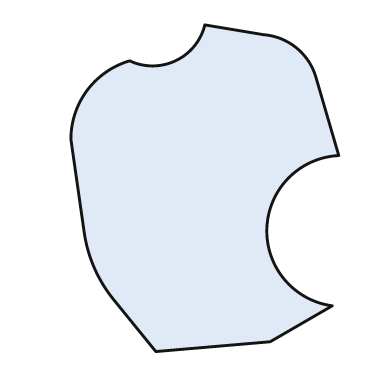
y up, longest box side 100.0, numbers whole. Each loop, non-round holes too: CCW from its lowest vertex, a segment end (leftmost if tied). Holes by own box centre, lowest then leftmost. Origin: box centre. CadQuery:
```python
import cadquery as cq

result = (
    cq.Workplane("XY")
    .moveTo(-15.0, -50.0)
    .lineTo(20.0, -47.0)
    .lineTo(39.0, -36.0)
    .threePointArc((19.0, -12.0), (41.0, 10.0))
    .lineTo(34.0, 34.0)
    .threePointArc((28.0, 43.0), (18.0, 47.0))
    .lineTo(0.0, 50.0)
    .threePointArc((-9.0, 39.0), (-23.0, 39.0))
    .threePointArc((-36.0, 30.0), (-41.0, 15.0))
    .lineTo(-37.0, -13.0)
    .threePointArc((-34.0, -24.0), (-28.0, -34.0))
    .close()
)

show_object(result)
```